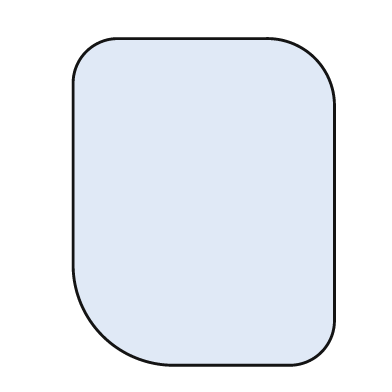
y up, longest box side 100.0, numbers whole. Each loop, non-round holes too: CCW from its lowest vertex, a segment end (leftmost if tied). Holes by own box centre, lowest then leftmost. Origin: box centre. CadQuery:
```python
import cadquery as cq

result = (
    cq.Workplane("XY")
    .moveTo(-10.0, -50.0)
    .lineTo(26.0, -50.0)
    .threePointArc((36.0, -46.0), (40.0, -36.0))
    .lineTo(40.0, 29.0)
    .threePointArc((34.0, 44.0), (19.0, 50.0))
    .lineTo(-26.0, 50.0)
    .threePointArc((-36.0, 46.0), (-40.0, 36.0))
    .lineTo(-40.0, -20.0)
    .threePointArc((-31.0, -41.0), (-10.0, -50.0))
    .close()
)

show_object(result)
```